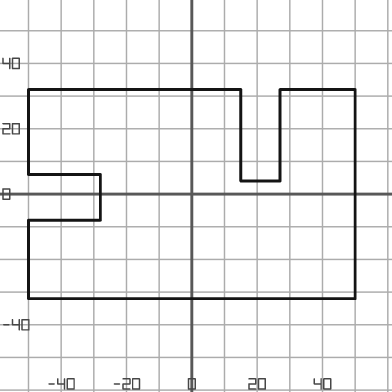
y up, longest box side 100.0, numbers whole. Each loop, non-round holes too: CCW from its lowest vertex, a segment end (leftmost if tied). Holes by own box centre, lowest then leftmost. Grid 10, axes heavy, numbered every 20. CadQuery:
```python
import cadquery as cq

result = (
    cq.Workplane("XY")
    .moveTo(-50.0, -32.0)
    .lineTo(50.0, -32.0)
    .lineTo(50.0, 32.0)
    .lineTo(27.0, 32.0)
    .lineTo(27.0, 4.0)
    .lineTo(15.0, 4.0)
    .lineTo(15.0, 32.0)
    .lineTo(-50.0, 32.0)
    .lineTo(-50.0, 6.0)
    .lineTo(-28.0, 6.0)
    .lineTo(-28.0, -8.0)
    .lineTo(-50.0, -8.0)
    .close()
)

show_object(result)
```